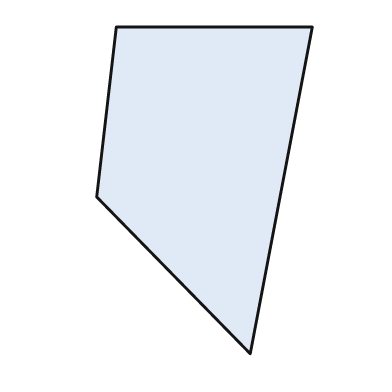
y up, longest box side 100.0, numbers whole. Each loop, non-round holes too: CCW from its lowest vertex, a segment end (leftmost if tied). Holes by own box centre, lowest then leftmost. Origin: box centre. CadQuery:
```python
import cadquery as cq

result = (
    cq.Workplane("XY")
    .moveTo(14.0, -50.0)
    .lineTo(33.0, 50.0)
    .lineTo(-27.0, 50.0)
    .lineTo(-33.0, -2.0)
    .close()
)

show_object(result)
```